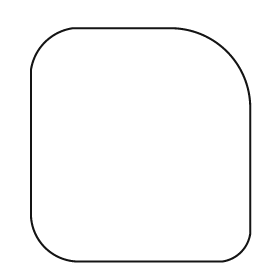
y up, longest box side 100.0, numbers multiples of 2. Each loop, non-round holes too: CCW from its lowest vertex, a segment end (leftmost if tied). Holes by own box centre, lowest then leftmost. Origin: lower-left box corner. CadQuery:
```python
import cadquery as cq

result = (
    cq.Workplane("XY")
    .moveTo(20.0, 0.0)
    .lineTo(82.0, 0.0)
    .threePointArc((90.0, 4.0), (94.0, 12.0))
    .lineTo(94.0, 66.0)
    .threePointArc((84.0, 90.0), (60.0, 100.0))
    .lineTo(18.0, 100.0)
    .threePointArc((6.0, 94.0), (0.0, 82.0))
    .lineTo(0.0, 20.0)
    .threePointArc((6.0, 6.0), (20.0, 0.0))
    .close()
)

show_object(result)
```